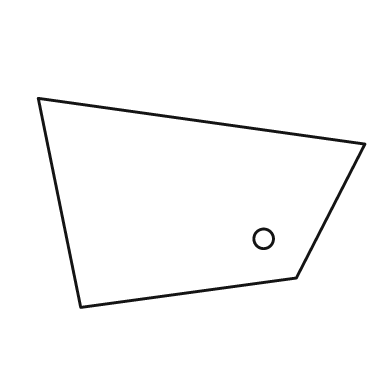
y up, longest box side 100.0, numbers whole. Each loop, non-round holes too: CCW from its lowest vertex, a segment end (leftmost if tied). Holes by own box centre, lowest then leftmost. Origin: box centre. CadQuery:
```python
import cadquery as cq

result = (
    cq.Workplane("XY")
    .moveTo(-37.0, -32.0)
    .lineTo(29.0, -23.0)
    .lineTo(50.0, 18.0)
    .lineTo(-50.0, 32.0)
    .close()
    .moveTo(19.0, -11.0)
    .circle(3.0)
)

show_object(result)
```